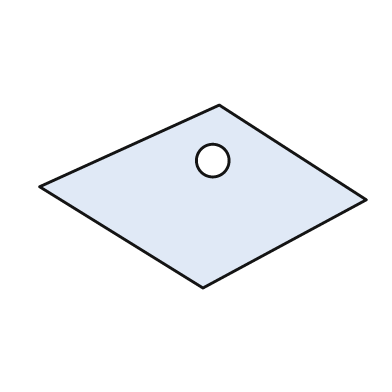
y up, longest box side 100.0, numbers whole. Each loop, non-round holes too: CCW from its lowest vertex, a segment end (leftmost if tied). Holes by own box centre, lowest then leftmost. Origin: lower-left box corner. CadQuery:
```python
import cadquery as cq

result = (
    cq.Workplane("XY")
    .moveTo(50.0, 0.0)
    .lineTo(100.0, 27.0)
    .lineTo(55.0, 56.0)
    .lineTo(0.0, 31.0)
    .close()
    .moveTo(53.0, 39.0)
    .circle(5.0)
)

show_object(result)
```